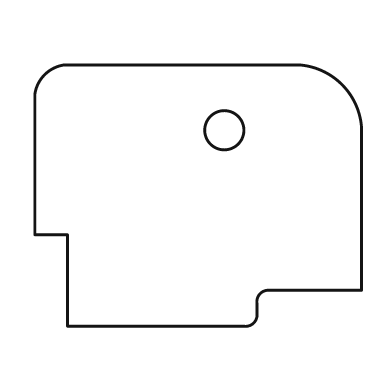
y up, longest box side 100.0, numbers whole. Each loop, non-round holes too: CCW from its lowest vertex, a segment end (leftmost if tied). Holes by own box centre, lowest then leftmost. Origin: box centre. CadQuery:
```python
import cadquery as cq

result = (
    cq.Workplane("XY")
    .moveTo(-40.0, -40.0)
    .lineTo(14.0, -40.0)
    .threePointArc((17.0, -39.0), (18.0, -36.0))
    .lineTo(18.0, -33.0)
    .threePointArc((19.0, -30.0), (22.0, -29.0))
    .lineTo(50.0, -29.0)
    .lineTo(50.0, 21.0)
    .threePointArc((44.0, 34.0), (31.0, 40.0))
    .lineTo(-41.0, 40.0)
    .threePointArc((-47.0, 37.0), (-50.0, 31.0))
    .lineTo(-50.0, -12.0)
    .lineTo(-40.0, -12.0)
    .close()
    .moveTo(8.0, 20.0)
    .circle(6.0)
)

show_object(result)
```